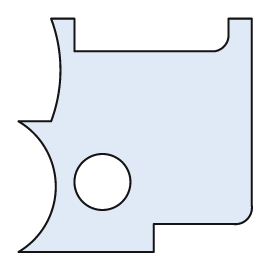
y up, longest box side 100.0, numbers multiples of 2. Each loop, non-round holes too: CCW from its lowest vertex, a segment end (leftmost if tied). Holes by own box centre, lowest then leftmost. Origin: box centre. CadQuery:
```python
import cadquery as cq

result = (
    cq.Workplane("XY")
    .moveTo(-50.0, -50.0)
    .lineTo(8.0, -50.0)
    .lineTo(8.0, -38.0)
    .lineTo(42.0, -38.0)
    .threePointArc((48.0, -36.0), (50.0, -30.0))
    .lineTo(50.0, 50.0)
    .lineTo(40.0, 50.0)
    .lineTo(40.0, 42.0)
    .threePointArc((38.0, 38.0), (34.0, 36.0))
    .lineTo(-26.0, 36.0)
    .lineTo(-26.0, 50.0)
    .lineTo(-36.0, 50.0)
    .threePointArc((-32.0, 28.0), (-36.0, 6.0))
    .lineTo(-50.0, 6.0)
    .threePointArc((-34.0, -22.0), (-50.0, -50.0))
    .close()
    .moveTo(-14.0, -20.0)
    .circle(12.0)
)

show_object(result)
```